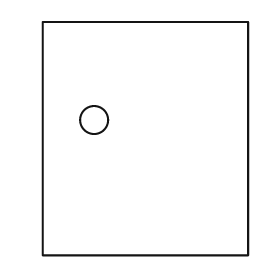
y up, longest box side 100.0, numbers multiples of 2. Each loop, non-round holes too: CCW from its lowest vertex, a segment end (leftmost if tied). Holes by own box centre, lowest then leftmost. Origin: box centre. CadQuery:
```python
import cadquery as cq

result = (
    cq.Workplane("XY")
    .moveTo(-44.0, -50.0)
    .lineTo(44.0, -50.0)
    .lineTo(44.0, 50.0)
    .lineTo(-44.0, 50.0)
    .close()
    .moveTo(-22.0, 8.0)
    .circle(6.0)
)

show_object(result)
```